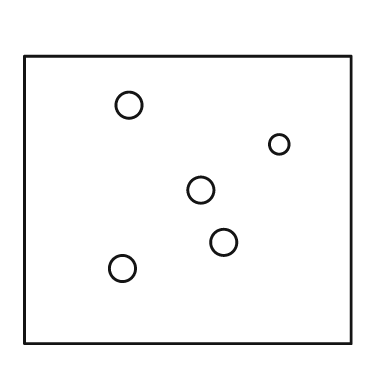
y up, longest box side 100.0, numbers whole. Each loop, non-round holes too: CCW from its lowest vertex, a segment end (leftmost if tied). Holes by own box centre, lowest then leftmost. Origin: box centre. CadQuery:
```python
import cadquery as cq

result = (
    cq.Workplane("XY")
    .moveTo(-50.0, -44.0)
    .lineTo(50.0, -44.0)
    .lineTo(50.0, 44.0)
    .lineTo(-50.0, 44.0)
    .close()
    .moveTo(-20.0, -21.0)
    .circle(4.0)
    .moveTo(11.0, -13.0)
    .circle(4.0)
    .moveTo(4.0, 3.0)
    .circle(4.0)
    .moveTo(28.0, 17.0)
    .circle(3.0)
    .moveTo(-18.0, 29.0)
    .circle(4.0)
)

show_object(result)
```